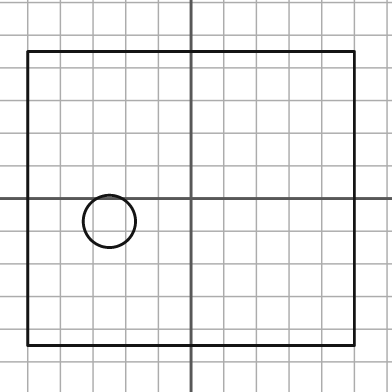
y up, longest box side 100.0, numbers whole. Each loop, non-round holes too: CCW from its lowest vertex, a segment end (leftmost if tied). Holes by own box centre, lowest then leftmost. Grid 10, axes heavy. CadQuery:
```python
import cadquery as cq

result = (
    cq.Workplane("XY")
    .moveTo(-50.0, -45.0)
    .lineTo(50.0, -45.0)
    .lineTo(50.0, 45.0)
    .lineTo(-50.0, 45.0)
    .close()
    .moveTo(-25.0, -7.0)
    .circle(8.0)
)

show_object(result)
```